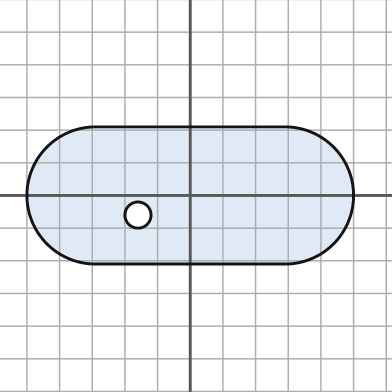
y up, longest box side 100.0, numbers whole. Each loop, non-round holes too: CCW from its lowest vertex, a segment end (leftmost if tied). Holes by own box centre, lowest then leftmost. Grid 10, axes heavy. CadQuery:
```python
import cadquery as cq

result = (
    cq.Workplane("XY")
    .moveTo(-29.0, -21.0)
    .lineTo(29.0, -21.0)
    .threePointArc((50.0, 0.0), (29.0, 21.0))
    .lineTo(-29.0, 21.0)
    .threePointArc((-50.0, 0.0), (-29.0, -21.0))
    .close()
    .moveTo(-16.0, -6.0)
    .circle(4.0)
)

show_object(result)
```